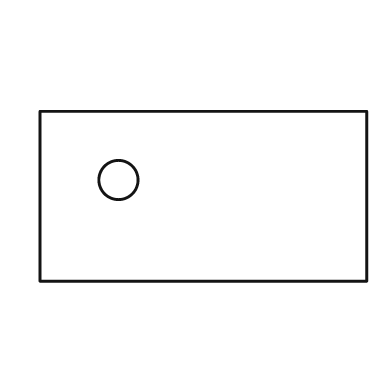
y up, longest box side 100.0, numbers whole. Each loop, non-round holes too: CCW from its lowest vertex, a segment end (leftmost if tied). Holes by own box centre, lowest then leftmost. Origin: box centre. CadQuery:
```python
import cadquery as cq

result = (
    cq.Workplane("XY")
    .moveTo(-50.0, -26.0)
    .lineTo(50.0, -26.0)
    .lineTo(50.0, 26.0)
    .lineTo(-50.0, 26.0)
    .close()
    .moveTo(-26.0, 5.0)
    .circle(6.0)
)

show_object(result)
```